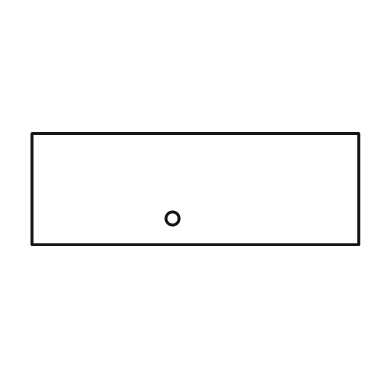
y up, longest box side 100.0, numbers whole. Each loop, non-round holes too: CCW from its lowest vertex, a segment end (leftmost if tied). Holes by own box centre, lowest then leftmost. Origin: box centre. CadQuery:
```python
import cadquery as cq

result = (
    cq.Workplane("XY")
    .moveTo(-50.0, -17.0)
    .lineTo(50.0, -17.0)
    .lineTo(50.0, 17.0)
    .lineTo(-50.0, 17.0)
    .close()
    .moveTo(-7.0, -9.0)
    .circle(2.0)
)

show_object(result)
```